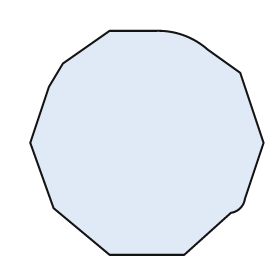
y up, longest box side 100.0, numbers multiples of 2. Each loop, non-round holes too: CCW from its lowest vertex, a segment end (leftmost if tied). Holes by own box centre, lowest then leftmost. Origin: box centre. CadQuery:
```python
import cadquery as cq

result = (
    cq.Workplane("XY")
    .moveTo(-16.0, -48.0)
    .lineTo(16.0, -48.0)
    .lineTo(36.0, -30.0)
    .threePointArc((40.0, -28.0), (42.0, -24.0))
    .lineTo(50.0, 0.0)
    .lineTo(40.0, 30.0)
    .lineTo(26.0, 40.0)
    .threePointArc((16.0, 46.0), (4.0, 48.0))
    .lineTo(-16.0, 48.0)
    .lineTo(-36.0, 34.0)
    .lineTo(-42.0, 24.0)
    .lineTo(-50.0, 0.0)
    .lineTo(-40.0, -28.0)
    .close()
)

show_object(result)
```